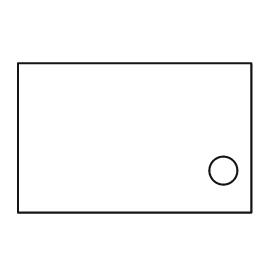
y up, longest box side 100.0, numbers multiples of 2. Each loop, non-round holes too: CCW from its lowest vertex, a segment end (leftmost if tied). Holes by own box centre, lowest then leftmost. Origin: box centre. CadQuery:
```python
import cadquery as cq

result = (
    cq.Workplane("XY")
    .moveTo(-50.0, -32.0)
    .lineTo(50.0, -32.0)
    .lineTo(50.0, 32.0)
    .lineTo(-50.0, 32.0)
    .close()
    .moveTo(38.0, -14.0)
    .circle(6.0)
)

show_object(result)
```